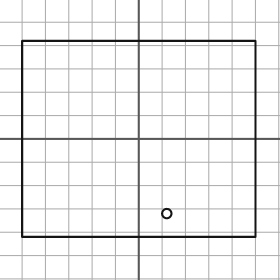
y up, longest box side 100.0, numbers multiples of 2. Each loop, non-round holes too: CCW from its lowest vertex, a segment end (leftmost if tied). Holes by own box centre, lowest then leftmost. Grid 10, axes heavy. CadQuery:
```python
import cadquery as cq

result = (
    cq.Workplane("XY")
    .moveTo(-50.0, -42.0)
    .lineTo(50.0, -42.0)
    .lineTo(50.0, 42.0)
    .lineTo(-50.0, 42.0)
    .close()
    .moveTo(12.0, -32.0)
    .circle(2.0)
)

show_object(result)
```